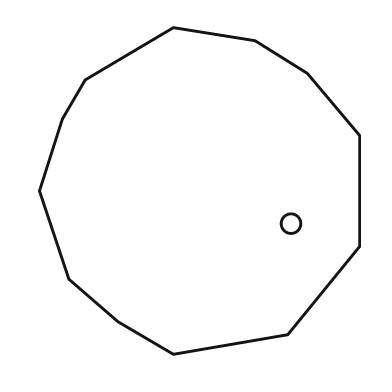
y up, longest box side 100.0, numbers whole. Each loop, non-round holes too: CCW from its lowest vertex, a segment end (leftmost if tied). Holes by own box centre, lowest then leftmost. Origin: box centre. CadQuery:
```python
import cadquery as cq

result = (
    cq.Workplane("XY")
    .moveTo(-8.0, -50.0)
    .lineTo(27.0, -44.0)
    .lineTo(49.0, -17.0)
    .lineTo(49.0, 17.0)
    .lineTo(33.0, 36.0)
    .lineTo(17.0, 46.0)
    .lineTo(-8.0, 50.0)
    .lineTo(-35.0, 34.0)
    .lineTo(-42.0, 22.0)
    .lineTo(-49.0, 0.0)
    .lineTo(-40.0, -27.0)
    .lineTo(-25.0, -40.0)
    .close()
    .moveTo(28.0, -10.0)
    .circle(3.0)
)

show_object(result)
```